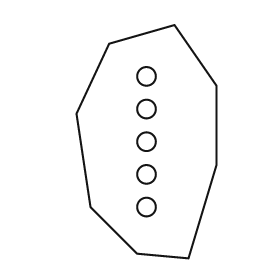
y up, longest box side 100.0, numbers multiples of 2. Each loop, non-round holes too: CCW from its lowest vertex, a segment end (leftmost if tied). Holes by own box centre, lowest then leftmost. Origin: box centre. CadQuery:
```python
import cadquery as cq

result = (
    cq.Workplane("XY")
    .moveTo(18.0, -50.0)
    .lineTo(30.0, -10.0)
    .lineTo(30.0, 24.0)
    .lineTo(12.0, 50.0)
    .lineTo(-16.0, 42.0)
    .lineTo(-30.0, 12.0)
    .lineTo(-24.0, -28.0)
    .lineTo(-4.0, -48.0)
    .close()
    .moveTo(0.0, -28.0)
    .circle(4.0)
    .moveTo(0.0, -14.0)
    .circle(4.0)
    .moveTo(0.0, 0.0)
    .circle(4.0)
    .moveTo(0.0, 14.0)
    .circle(4.0)
    .moveTo(0.0, 28.0)
    .circle(4.0)
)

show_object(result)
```